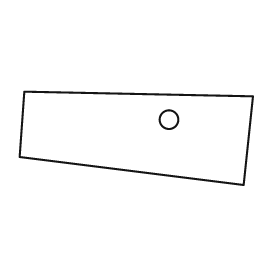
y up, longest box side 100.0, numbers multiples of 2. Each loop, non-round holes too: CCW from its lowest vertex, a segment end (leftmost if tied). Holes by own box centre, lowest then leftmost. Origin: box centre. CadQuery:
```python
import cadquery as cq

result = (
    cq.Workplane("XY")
    .moveTo(46.0, -20.0)
    .lineTo(50.0, 18.0)
    .lineTo(-48.0, 20.0)
    .lineTo(-50.0, -8.0)
    .close()
    .moveTo(14.0, 8.0)
    .circle(4.0)
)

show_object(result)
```